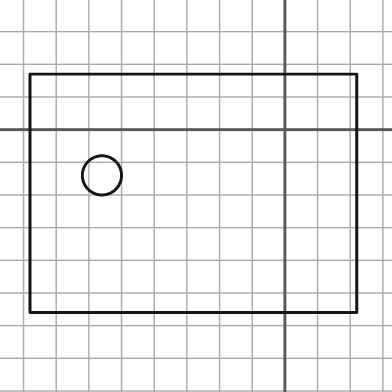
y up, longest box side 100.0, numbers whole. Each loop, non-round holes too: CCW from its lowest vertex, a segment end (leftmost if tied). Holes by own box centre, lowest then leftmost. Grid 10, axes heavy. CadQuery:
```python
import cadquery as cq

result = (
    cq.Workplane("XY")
    .moveTo(-78.0, -56.0)
    .lineTo(22.0, -56.0)
    .lineTo(22.0, 17.0)
    .lineTo(-78.0, 17.0)
    .close()
    .moveTo(-56.0, -14.0)
    .circle(6.0)
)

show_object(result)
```